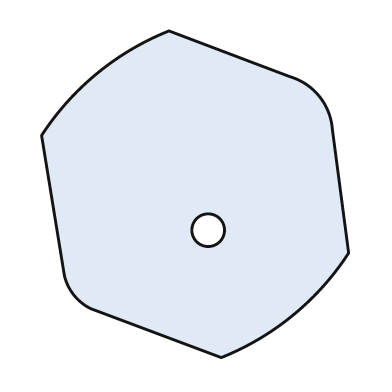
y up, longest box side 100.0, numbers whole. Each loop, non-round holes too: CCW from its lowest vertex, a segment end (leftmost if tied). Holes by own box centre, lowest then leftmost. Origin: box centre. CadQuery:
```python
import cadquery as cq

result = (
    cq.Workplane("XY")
    .moveTo(8.0, -50.0)
    .threePointArc((30.0, -37.0), (47.0, -18.0))
    .lineTo(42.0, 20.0)
    .threePointArc((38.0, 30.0), (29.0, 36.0))
    .lineTo(-8.0, 50.0)
    .threePointArc((-30.0, 37.0), (-47.0, 18.0))
    .lineTo(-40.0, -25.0)
    .threePointArc((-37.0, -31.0), (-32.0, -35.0))
    .close()
    .moveTo(4.0, -11.0)
    .circle(5.0)
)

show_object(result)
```